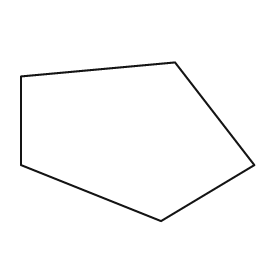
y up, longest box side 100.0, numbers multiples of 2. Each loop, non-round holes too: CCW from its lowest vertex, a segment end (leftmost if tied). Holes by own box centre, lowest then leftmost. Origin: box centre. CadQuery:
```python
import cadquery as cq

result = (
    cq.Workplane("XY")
    .moveTo(10.0, -34.0)
    .lineTo(50.0, -10.0)
    .lineTo(16.0, 34.0)
    .lineTo(-50.0, 28.0)
    .lineTo(-50.0, -10.0)
    .close()
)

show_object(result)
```